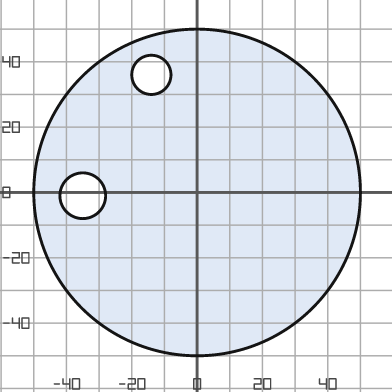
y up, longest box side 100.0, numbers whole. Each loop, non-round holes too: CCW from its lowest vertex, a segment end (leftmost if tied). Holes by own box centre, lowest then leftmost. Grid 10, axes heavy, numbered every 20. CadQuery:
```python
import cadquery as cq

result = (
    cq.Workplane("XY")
    .moveTo(0.0, 0.0)
    .circle(50.0)
    .moveTo(-35.0, -1.0)
    .circle(7.0)
    .moveTo(-14.0, 36.0)
    .circle(6.0)
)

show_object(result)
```